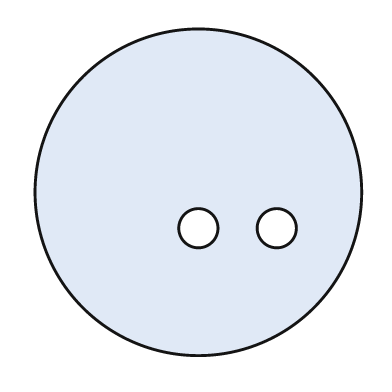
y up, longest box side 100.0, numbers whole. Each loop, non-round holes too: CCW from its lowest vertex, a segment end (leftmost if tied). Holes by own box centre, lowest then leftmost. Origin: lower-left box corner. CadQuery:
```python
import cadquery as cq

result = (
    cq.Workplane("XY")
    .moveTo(50.0, 50.0)
    .circle(50.0)
    .moveTo(50.0, 39.0)
    .circle(6.0)
    .moveTo(74.0, 39.0)
    .circle(6.0)
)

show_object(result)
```